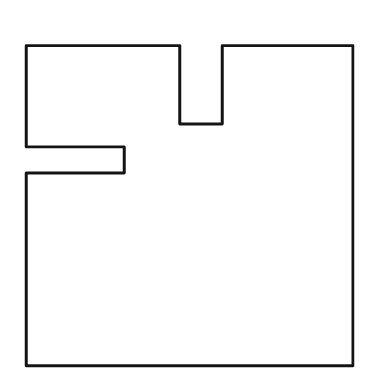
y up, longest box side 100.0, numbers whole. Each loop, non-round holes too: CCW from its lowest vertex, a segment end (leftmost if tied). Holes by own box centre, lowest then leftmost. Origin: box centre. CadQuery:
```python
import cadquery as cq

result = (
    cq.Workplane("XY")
    .moveTo(-50.0, -49.0)
    .lineTo(50.0, -49.0)
    .lineTo(50.0, 49.0)
    .lineTo(10.0, 49.0)
    .lineTo(10.0, 25.0)
    .lineTo(-3.0, 25.0)
    .lineTo(-3.0, 49.0)
    .lineTo(-50.0, 49.0)
    .lineTo(-50.0, 18.0)
    .lineTo(-20.0, 18.0)
    .lineTo(-20.0, 10.0)
    .lineTo(-50.0, 10.0)
    .close()
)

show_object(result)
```